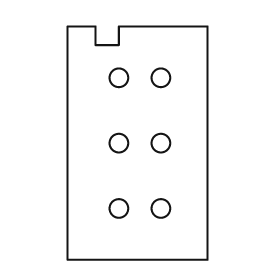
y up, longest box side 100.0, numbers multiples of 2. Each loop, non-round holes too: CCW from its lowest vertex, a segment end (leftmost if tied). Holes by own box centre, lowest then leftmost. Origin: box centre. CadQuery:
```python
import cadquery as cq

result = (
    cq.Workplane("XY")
    .moveTo(-30.0, -50.0)
    .lineTo(30.0, -50.0)
    .lineTo(30.0, 50.0)
    .lineTo(-8.0, 50.0)
    .lineTo(-8.0, 42.0)
    .lineTo(-18.0, 42.0)
    .lineTo(-18.0, 50.0)
    .lineTo(-30.0, 50.0)
    .close()
    .moveTo(-8.0, -28.0)
    .circle(4.0)
    .moveTo(10.0, -28.0)
    .circle(4.0)
    .moveTo(-8.0, 0.0)
    .circle(4.0)
    .moveTo(10.0, 0.0)
    .circle(4.0)
    .moveTo(-8.0, 28.0)
    .circle(4.0)
    .moveTo(10.0, 28.0)
    .circle(4.0)
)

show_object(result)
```